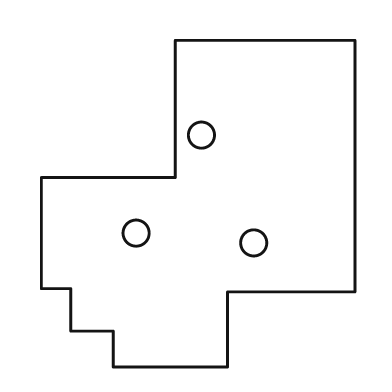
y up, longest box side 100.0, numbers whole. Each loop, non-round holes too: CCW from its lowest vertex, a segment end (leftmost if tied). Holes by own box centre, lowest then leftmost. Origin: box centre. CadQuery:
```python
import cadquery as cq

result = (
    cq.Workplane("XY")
    .moveTo(-26.0, -50.0)
    .lineTo(9.0, -50.0)
    .lineTo(9.0, -27.0)
    .lineTo(48.0, -27.0)
    .lineTo(48.0, 50.0)
    .lineTo(-7.0, 50.0)
    .lineTo(-7.0, 8.0)
    .lineTo(-48.0, 8.0)
    .lineTo(-48.0, -26.0)
    .lineTo(-39.0, -26.0)
    .lineTo(-39.0, -39.0)
    .lineTo(-26.0, -39.0)
    .close()
    .moveTo(17.0, -12.0)
    .circle(4.0)
    .moveTo(-19.0, -9.0)
    .circle(4.0)
    .moveTo(1.0, 21.0)
    .circle(4.0)
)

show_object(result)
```